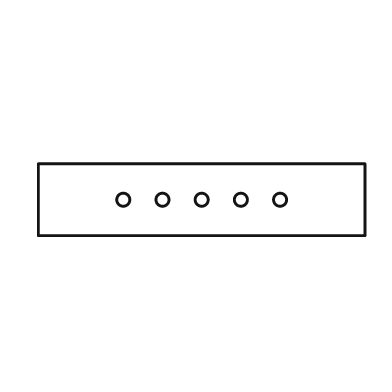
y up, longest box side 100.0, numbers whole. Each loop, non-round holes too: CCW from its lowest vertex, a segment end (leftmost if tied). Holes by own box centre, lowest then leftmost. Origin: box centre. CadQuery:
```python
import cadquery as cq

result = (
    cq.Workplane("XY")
    .moveTo(-50.0, -11.0)
    .lineTo(50.0, -11.0)
    .lineTo(50.0, 11.0)
    .lineTo(-50.0, 11.0)
    .close()
    .moveTo(-24.0, 0.0)
    .circle(2.0)
    .moveTo(-12.0, 0.0)
    .circle(2.0)
    .moveTo(0.0, 0.0)
    .circle(2.0)
    .moveTo(12.0, 0.0)
    .circle(2.0)
    .moveTo(24.0, 0.0)
    .circle(2.0)
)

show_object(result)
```